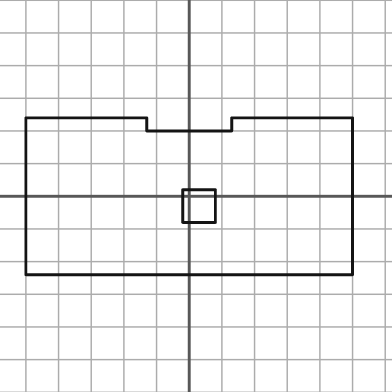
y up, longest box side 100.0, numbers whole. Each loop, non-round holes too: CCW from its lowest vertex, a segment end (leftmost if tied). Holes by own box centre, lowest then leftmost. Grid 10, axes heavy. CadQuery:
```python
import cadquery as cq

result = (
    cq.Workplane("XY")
    .moveTo(-50.0, -24.0)
    .lineTo(50.0, -24.0)
    .lineTo(50.0, 24.0)
    .lineTo(13.0, 24.0)
    .lineTo(13.0, 20.0)
    .lineTo(-13.0, 20.0)
    .lineTo(-13.0, 24.0)
    .lineTo(-50.0, 24.0)
    .close()
    .moveTo(-2.0, -8.0)
    .lineTo(8.0, -8.0)
    .lineTo(8.0, 2.0)
    .lineTo(-2.0, 2.0)
    .close()
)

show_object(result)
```